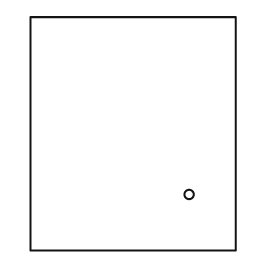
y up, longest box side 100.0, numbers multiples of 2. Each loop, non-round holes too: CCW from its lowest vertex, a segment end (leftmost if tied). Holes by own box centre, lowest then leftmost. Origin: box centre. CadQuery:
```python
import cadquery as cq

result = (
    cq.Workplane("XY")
    .moveTo(-44.0, -50.0)
    .lineTo(44.0, -50.0)
    .lineTo(44.0, 50.0)
    .lineTo(-44.0, 50.0)
    .close()
    .moveTo(24.0, -26.0)
    .circle(2.0)
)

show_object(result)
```